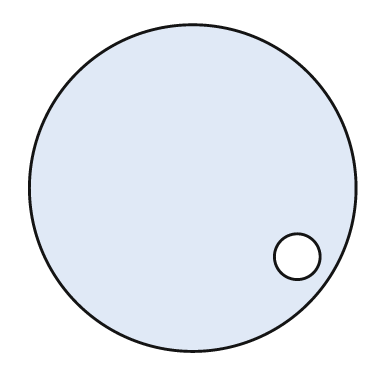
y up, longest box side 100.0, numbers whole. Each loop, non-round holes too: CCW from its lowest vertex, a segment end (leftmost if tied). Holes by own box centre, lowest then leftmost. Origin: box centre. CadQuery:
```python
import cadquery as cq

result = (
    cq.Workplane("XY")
    .moveTo(0.0, 0.0)
    .circle(50.0)
    .moveTo(32.0, -21.0)
    .circle(7.0)
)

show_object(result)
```